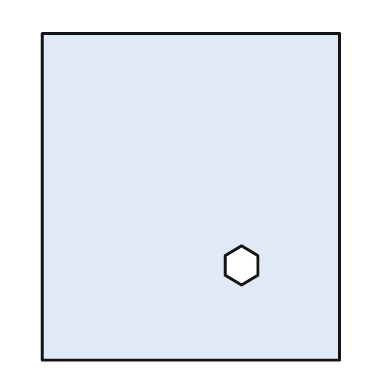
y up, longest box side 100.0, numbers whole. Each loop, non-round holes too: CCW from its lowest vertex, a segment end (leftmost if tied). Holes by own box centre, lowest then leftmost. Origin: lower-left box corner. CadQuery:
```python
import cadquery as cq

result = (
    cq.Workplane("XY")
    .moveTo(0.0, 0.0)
    .lineTo(91.0, 0.0)
    .lineTo(91.0, 100.0)
    .lineTo(0.0, 100.0)
    .close()
    .moveTo(61.0, 23.0)
    .lineTo(66.0, 26.0)
    .lineTo(66.0, 32.0)
    .lineTo(61.0, 35.0)
    .lineTo(56.0, 32.0)
    .lineTo(56.0, 26.0)
    .close()
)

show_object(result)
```